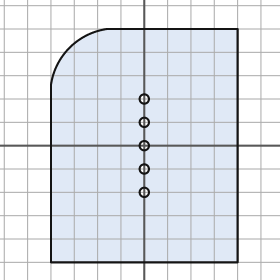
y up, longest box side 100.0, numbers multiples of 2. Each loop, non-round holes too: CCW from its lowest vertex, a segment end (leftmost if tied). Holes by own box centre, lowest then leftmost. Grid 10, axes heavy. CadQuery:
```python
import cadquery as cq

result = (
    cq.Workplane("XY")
    .moveTo(-40.0, -50.0)
    .lineTo(40.0, -50.0)
    .lineTo(40.0, 50.0)
    .lineTo(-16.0, 50.0)
    .threePointArc((-32.0, 42.0), (-40.0, 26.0))
    .close()
    .moveTo(0.0, -20.0)
    .circle(2.0)
    .moveTo(0.0, -10.0)
    .circle(2.0)
    .moveTo(0.0, 0.0)
    .circle(2.0)
    .moveTo(0.0, 10.0)
    .circle(2.0)
    .moveTo(0.0, 20.0)
    .circle(2.0)
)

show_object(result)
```